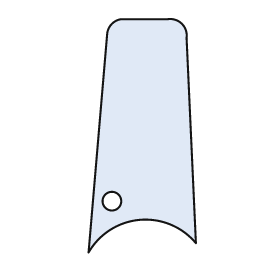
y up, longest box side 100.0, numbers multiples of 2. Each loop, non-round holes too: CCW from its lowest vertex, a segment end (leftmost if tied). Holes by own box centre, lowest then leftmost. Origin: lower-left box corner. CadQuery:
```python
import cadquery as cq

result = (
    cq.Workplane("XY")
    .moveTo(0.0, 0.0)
    .threePointArc((22.0, 14.0), (46.0, 4.0))
    .lineTo(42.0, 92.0)
    .threePointArc((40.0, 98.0), (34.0, 100.0))
    .lineTo(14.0, 100.0)
    .threePointArc((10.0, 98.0), (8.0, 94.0))
    .close()
    .moveTo(10.0, 22.0)
    .circle(4.0)
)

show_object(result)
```